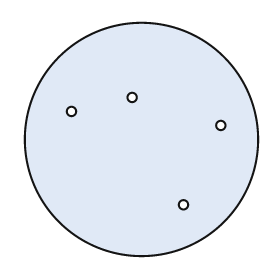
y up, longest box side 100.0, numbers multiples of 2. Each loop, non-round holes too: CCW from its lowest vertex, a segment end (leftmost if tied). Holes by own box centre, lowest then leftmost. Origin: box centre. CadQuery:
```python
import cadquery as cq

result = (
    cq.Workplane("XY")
    .moveTo(0.0, 0.0)
    .circle(50.0)
    .moveTo(18.0, -28.0)
    .circle(2.0)
    .moveTo(34.0, 6.0)
    .circle(2.0)
    .moveTo(-30.0, 12.0)
    .circle(2.0)
    .moveTo(-4.0, 18.0)
    .circle(2.0)
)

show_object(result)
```